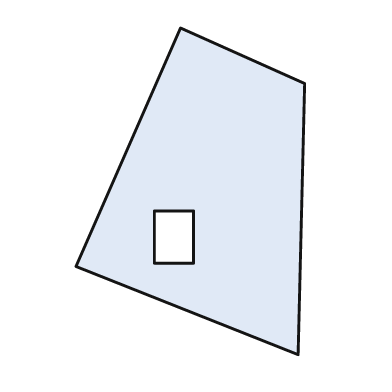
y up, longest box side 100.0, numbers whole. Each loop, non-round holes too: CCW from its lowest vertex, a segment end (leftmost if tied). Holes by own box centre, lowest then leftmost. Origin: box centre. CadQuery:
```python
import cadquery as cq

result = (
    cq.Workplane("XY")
    .moveTo(33.0, -50.0)
    .lineTo(35.0, 33.0)
    .lineTo(-3.0, 50.0)
    .lineTo(-35.0, -23.0)
    .close()
    .moveTo(-11.0, -22.0)
    .lineTo(1.0, -22.0)
    .lineTo(1.0, -6.0)
    .lineTo(-11.0, -6.0)
    .close()
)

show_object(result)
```